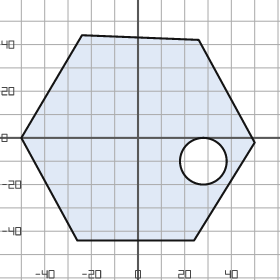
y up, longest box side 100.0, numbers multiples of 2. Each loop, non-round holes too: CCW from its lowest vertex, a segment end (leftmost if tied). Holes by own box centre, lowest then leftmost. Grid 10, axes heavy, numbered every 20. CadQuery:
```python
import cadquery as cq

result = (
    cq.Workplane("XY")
    .moveTo(-26.0, -44.0)
    .lineTo(24.0, -44.0)
    .lineTo(50.0, -2.0)
    .lineTo(26.0, 42.0)
    .lineTo(-24.0, 44.0)
    .lineTo(-50.0, 0.0)
    .close()
    .moveTo(28.0, -10.0)
    .circle(10.0)
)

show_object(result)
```